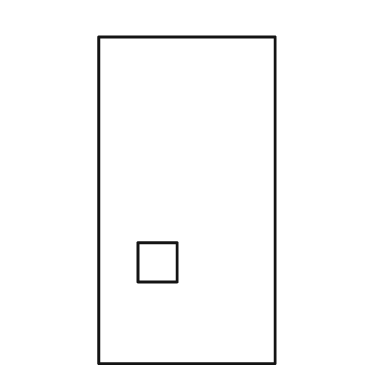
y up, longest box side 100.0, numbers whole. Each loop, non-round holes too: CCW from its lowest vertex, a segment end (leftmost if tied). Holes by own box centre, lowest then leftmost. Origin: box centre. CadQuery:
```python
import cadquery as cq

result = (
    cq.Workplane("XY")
    .moveTo(-27.0, -50.0)
    .lineTo(27.0, -50.0)
    .lineTo(27.0, 50.0)
    .lineTo(-27.0, 50.0)
    .close()
    .moveTo(-15.0, -25.0)
    .lineTo(-3.0, -25.0)
    .lineTo(-3.0, -13.0)
    .lineTo(-15.0, -13.0)
    .close()
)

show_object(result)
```